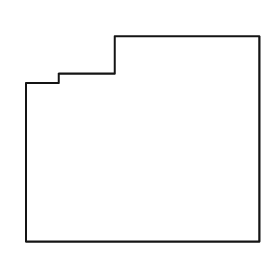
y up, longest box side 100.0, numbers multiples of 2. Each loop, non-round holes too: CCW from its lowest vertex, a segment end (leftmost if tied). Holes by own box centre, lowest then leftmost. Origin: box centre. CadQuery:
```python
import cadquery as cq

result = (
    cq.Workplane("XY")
    .moveTo(-50.0, -44.0)
    .lineTo(50.0, -44.0)
    .lineTo(50.0, 44.0)
    .lineTo(-12.0, 44.0)
    .lineTo(-12.0, 28.0)
    .lineTo(-36.0, 28.0)
    .lineTo(-36.0, 24.0)
    .lineTo(-50.0, 24.0)
    .close()
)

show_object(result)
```